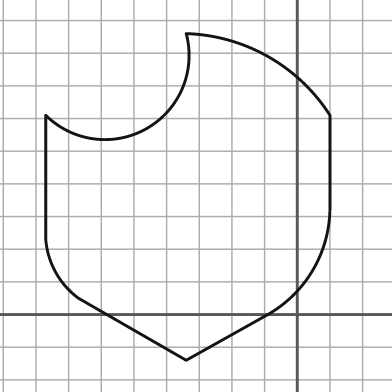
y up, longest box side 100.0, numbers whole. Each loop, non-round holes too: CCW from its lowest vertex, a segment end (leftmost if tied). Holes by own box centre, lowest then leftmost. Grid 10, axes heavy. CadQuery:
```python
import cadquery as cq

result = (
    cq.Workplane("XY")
    .moveTo(-34.0, -14.0)
    .lineTo(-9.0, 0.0)
    .threePointArc((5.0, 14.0), (10.0, 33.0))
    .lineTo(10.0, 61.0)
    .threePointArc((-9.0, 79.0), (-34.0, 86.0))
    .threePointArc((-46.0, 57.0), (-77.0, 61.0))
    .lineTo(-77.0, 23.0)
    .threePointArc((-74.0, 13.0), (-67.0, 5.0))
    .close()
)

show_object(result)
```